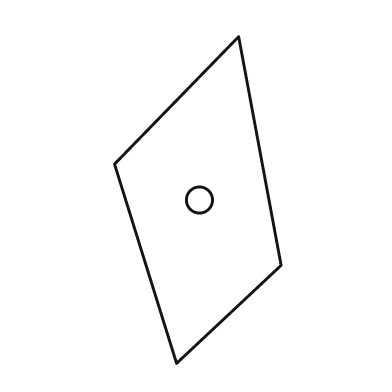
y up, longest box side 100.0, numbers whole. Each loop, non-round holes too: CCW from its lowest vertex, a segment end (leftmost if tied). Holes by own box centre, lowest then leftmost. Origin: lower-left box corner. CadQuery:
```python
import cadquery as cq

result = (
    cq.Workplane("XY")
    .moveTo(19.0, 0.0)
    .lineTo(51.0, 30.0)
    .lineTo(38.0, 100.0)
    .lineTo(0.0, 61.0)
    .close()
    .moveTo(26.0, 50.0)
    .circle(4.0)
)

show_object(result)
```